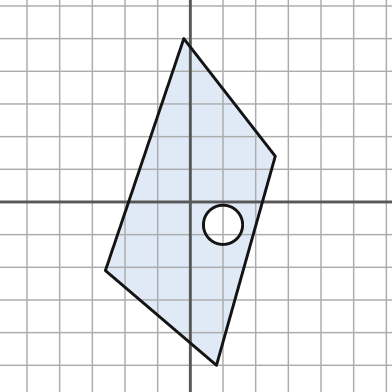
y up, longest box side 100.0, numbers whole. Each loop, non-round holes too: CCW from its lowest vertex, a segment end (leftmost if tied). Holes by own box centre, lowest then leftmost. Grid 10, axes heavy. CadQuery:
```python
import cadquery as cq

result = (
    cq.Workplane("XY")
    .moveTo(8.0, -50.0)
    .lineTo(26.0, 14.0)
    .lineTo(-2.0, 50.0)
    .lineTo(-26.0, -21.0)
    .close()
    .moveTo(10.0, -7.0)
    .circle(6.0)
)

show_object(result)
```